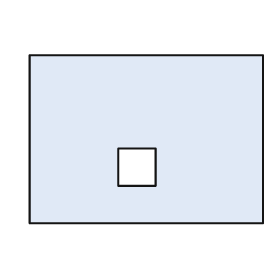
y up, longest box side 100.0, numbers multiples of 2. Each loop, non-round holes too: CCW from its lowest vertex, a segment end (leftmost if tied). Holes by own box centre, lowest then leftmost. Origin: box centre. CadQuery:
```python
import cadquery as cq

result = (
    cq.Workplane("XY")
    .moveTo(-50.0, -36.0)
    .lineTo(50.0, -36.0)
    .lineTo(50.0, 36.0)
    .lineTo(-50.0, 36.0)
    .close()
    .moveTo(-12.0, -20.0)
    .lineTo(4.0, -20.0)
    .lineTo(4.0, -4.0)
    .lineTo(-12.0, -4.0)
    .close()
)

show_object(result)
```